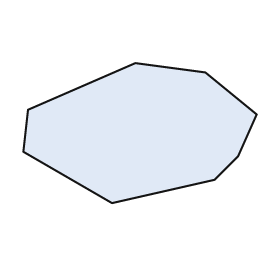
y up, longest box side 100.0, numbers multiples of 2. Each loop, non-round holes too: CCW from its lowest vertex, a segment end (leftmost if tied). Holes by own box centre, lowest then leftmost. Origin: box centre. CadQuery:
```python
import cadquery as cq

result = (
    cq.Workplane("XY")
    .moveTo(-12.0, -30.0)
    .lineTo(32.0, -20.0)
    .lineTo(42.0, -10.0)
    .lineTo(50.0, 8.0)
    .lineTo(28.0, 26.0)
    .lineTo(-2.0, 30.0)
    .lineTo(-48.0, 10.0)
    .lineTo(-50.0, -8.0)
    .close()
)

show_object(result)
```